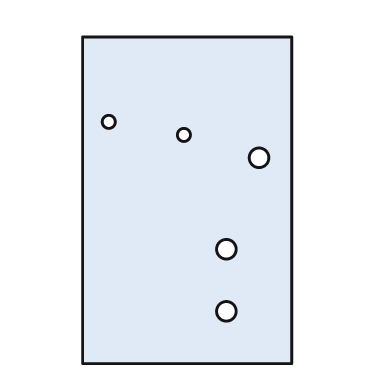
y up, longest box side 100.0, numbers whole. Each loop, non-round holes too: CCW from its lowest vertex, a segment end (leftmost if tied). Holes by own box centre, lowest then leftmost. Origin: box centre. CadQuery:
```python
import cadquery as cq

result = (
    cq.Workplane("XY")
    .moveTo(-32.0, -50.0)
    .lineTo(32.0, -50.0)
    .lineTo(32.0, 50.0)
    .lineTo(-32.0, 50.0)
    .close()
    .moveTo(12.0, -34.0)
    .circle(3.0)
    .moveTo(12.0, -15.0)
    .circle(3.0)
    .moveTo(22.0, 13.0)
    .circle(3.0)
    .moveTo(-1.0, 20.0)
    .circle(2.0)
    .moveTo(-24.0, 24.0)
    .circle(2.0)
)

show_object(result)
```